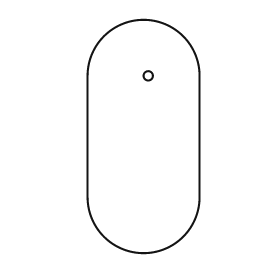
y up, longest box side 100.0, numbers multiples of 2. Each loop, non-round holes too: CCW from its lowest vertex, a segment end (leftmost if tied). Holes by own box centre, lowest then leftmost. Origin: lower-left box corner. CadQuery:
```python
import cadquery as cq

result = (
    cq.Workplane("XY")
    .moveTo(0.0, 24.0)
    .threePointArc((24.0, 0.0), (48.0, 24.0))
    .lineTo(48.0, 76.0)
    .threePointArc((24.0, 100.0), (0.0, 76.0))
    .close()
    .moveTo(26.0, 76.0)
    .circle(2.0)
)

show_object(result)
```